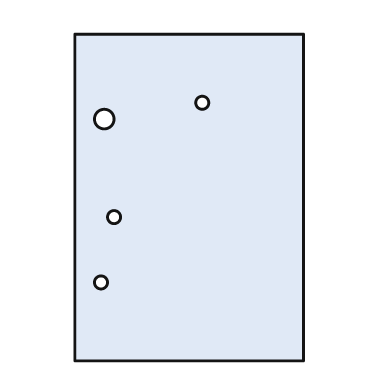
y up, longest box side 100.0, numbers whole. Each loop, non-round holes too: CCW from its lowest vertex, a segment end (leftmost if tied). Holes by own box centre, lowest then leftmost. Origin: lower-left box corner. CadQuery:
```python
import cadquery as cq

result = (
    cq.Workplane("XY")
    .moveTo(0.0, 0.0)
    .lineTo(70.0, 0.0)
    .lineTo(70.0, 100.0)
    .lineTo(0.0, 100.0)
    .close()
    .moveTo(8.0, 24.0)
    .circle(2.0)
    .moveTo(12.0, 44.0)
    .circle(2.0)
    .moveTo(9.0, 74.0)
    .circle(3.0)
    .moveTo(39.0, 79.0)
    .circle(2.0)
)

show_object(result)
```